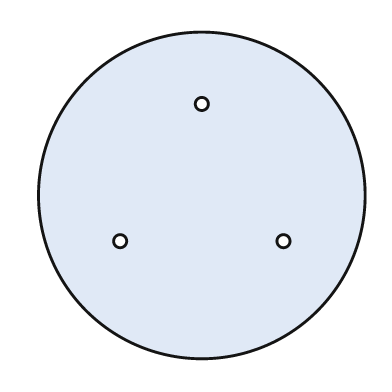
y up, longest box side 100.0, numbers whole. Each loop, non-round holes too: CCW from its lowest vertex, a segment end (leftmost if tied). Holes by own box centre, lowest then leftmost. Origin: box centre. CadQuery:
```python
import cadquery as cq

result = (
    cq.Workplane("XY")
    .moveTo(0.0, 0.0)
    .circle(50.0)
    .moveTo(-25.0, -14.0)
    .circle(2.0)
    .moveTo(25.0, -14.0)
    .circle(2.0)
    .moveTo(0.0, 28.0)
    .circle(2.0)
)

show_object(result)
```